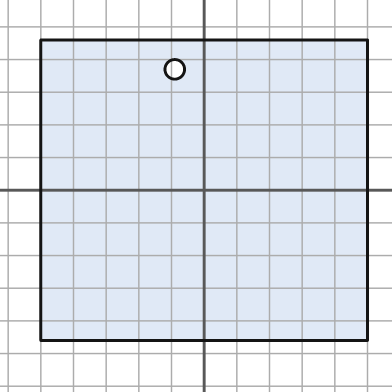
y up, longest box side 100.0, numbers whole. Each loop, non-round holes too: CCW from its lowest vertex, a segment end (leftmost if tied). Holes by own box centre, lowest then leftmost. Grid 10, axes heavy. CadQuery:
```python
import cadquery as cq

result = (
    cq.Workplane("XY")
    .moveTo(-50.0, -46.0)
    .lineTo(50.0, -46.0)
    .lineTo(50.0, 46.0)
    .lineTo(-50.0, 46.0)
    .close()
    .moveTo(-9.0, 37.0)
    .circle(3.0)
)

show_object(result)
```